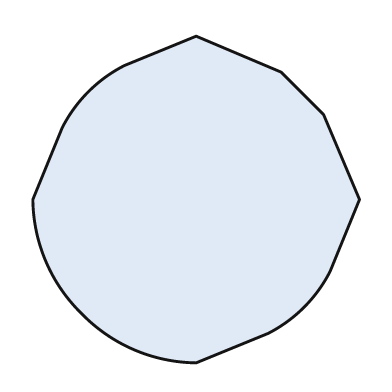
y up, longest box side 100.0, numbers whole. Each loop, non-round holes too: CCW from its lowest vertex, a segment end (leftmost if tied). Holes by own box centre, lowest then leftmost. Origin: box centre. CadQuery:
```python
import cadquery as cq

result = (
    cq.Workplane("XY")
    .moveTo(0.0, -50.0)
    .lineTo(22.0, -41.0)
    .threePointArc((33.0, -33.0), (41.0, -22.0))
    .lineTo(50.0, 0.0)
    .lineTo(39.0, 26.0)
    .lineTo(26.0, 39.0)
    .lineTo(0.0, 50.0)
    .lineTo(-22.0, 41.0)
    .threePointArc((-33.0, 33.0), (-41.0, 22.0))
    .lineTo(-50.0, 0.0)
    .threePointArc((-46.0, -19.0), (-35.0, -35.0))
    .threePointArc((-19.0, -46.0), (0.0, -50.0))
    .close()
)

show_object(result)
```